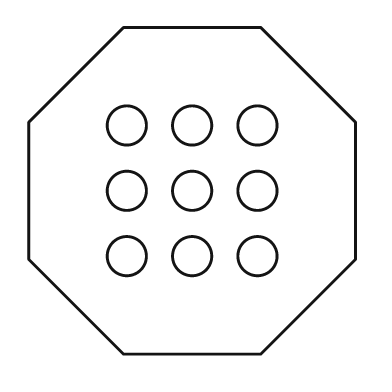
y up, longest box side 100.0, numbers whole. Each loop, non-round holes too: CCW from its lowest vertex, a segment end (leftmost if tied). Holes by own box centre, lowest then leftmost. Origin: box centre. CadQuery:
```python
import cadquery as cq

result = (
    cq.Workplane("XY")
    .moveTo(-21.0, -50.0)
    .lineTo(21.0, -50.0)
    .lineTo(50.0, -21.0)
    .lineTo(50.0, 21.0)
    .lineTo(21.0, 50.0)
    .lineTo(-21.0, 50.0)
    .lineTo(-50.0, 21.0)
    .lineTo(-50.0, -21.0)
    .close()
    .moveTo(-20.0, -20.0)
    .circle(6.0)
    .moveTo(0.0, -20.0)
    .circle(6.0)
    .moveTo(20.0, -20.0)
    .circle(6.0)
    .moveTo(-20.0, 0.0)
    .circle(6.0)
    .moveTo(0.0, 0.0)
    .circle(6.0)
    .moveTo(20.0, 0.0)
    .circle(6.0)
    .moveTo(-20.0, 20.0)
    .circle(6.0)
    .moveTo(0.0, 20.0)
    .circle(6.0)
    .moveTo(20.0, 20.0)
    .circle(6.0)
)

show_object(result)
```